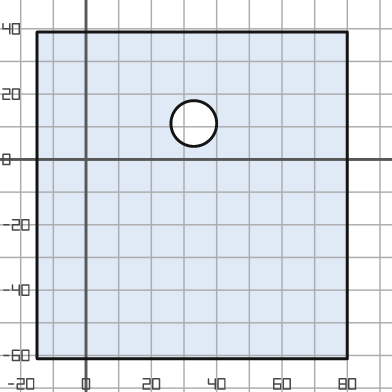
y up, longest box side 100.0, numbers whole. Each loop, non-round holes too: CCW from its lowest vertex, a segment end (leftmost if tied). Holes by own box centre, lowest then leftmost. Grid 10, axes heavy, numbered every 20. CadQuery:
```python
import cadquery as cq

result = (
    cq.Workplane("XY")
    .moveTo(-15.0, -61.0)
    .lineTo(80.0, -61.0)
    .lineTo(80.0, 39.0)
    .lineTo(-15.0, 39.0)
    .close()
    .moveTo(33.0, 11.0)
    .circle(7.0)
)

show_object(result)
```